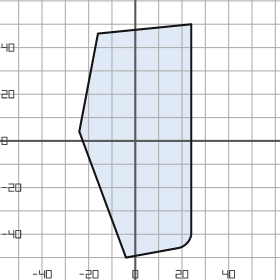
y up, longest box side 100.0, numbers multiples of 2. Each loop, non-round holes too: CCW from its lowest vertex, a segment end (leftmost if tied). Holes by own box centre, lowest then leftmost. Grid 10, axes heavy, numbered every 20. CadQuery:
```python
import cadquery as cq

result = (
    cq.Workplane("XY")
    .moveTo(-4.0, -50.0)
    .lineTo(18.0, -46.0)
    .threePointArc((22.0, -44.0), (24.0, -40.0))
    .lineTo(24.0, 50.0)
    .lineTo(-16.0, 46.0)
    .lineTo(-24.0, 4.0)
    .close()
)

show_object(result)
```